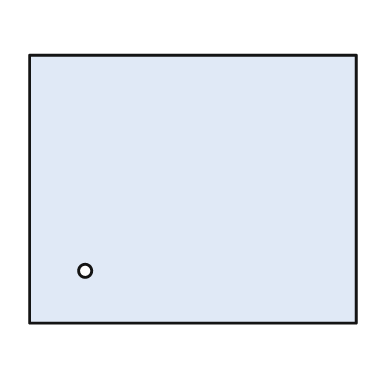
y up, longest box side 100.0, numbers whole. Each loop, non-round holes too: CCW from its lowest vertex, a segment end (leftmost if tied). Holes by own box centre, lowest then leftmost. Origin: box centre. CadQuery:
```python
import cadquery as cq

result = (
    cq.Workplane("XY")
    .moveTo(-50.0, -41.0)
    .lineTo(50.0, -41.0)
    .lineTo(50.0, 41.0)
    .lineTo(-50.0, 41.0)
    .close()
    .moveTo(-33.0, -25.0)
    .circle(2.0)
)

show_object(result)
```